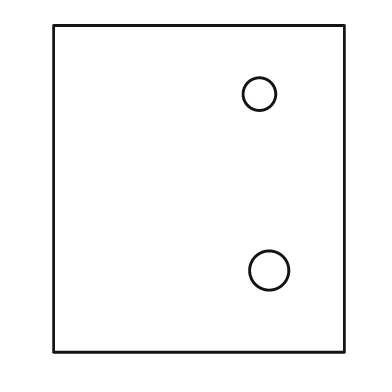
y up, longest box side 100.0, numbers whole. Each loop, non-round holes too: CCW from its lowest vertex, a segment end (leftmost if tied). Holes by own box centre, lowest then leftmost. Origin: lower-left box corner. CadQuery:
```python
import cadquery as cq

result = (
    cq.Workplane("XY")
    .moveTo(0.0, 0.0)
    .lineTo(89.0, 0.0)
    .lineTo(89.0, 100.0)
    .lineTo(0.0, 100.0)
    .close()
    .moveTo(66.0, 25.0)
    .circle(6.0)
    .moveTo(63.0, 79.0)
    .circle(5.0)
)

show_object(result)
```